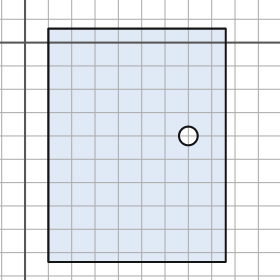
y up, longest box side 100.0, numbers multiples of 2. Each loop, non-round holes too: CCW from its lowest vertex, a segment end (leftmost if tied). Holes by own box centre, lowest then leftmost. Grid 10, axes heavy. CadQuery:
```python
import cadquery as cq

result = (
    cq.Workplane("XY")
    .moveTo(10.0, -94.0)
    .lineTo(86.0, -94.0)
    .lineTo(86.0, 6.0)
    .lineTo(10.0, 6.0)
    .close()
    .moveTo(70.0, -40.0)
    .circle(4.0)
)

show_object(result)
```